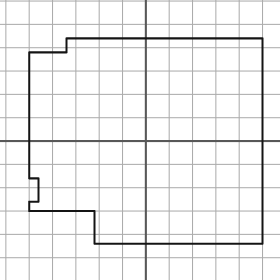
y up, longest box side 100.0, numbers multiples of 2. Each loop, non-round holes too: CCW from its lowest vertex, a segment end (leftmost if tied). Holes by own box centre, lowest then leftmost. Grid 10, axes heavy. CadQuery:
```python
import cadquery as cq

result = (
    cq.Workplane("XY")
    .moveTo(-22.0, -44.0)
    .lineTo(50.0, -44.0)
    .lineTo(50.0, 44.0)
    .lineTo(-34.0, 44.0)
    .lineTo(-34.0, 38.0)
    .lineTo(-50.0, 38.0)
    .lineTo(-50.0, -16.0)
    .lineTo(-46.0, -16.0)
    .lineTo(-46.0, -26.0)
    .lineTo(-50.0, -26.0)
    .lineTo(-50.0, -30.0)
    .lineTo(-22.0, -30.0)
    .close()
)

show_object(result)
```